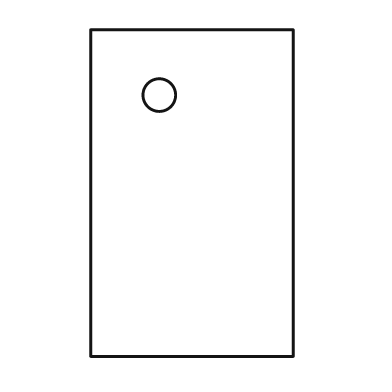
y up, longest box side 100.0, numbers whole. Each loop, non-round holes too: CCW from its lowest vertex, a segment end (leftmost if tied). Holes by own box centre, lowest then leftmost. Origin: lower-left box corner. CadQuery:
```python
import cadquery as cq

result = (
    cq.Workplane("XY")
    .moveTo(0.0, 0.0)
    .lineTo(62.0, 0.0)
    .lineTo(62.0, 100.0)
    .lineTo(0.0, 100.0)
    .close()
    .moveTo(21.0, 80.0)
    .circle(5.0)
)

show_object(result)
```